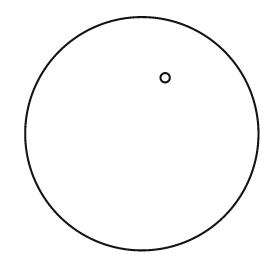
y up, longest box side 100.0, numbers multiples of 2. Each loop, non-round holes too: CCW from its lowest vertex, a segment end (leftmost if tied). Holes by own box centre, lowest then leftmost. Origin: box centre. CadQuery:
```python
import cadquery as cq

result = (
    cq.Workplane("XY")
    .moveTo(0.0, 0.0)
    .circle(50.0)
    .moveTo(10.0, 24.0)
    .circle(2.0)
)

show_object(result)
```